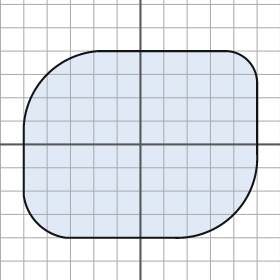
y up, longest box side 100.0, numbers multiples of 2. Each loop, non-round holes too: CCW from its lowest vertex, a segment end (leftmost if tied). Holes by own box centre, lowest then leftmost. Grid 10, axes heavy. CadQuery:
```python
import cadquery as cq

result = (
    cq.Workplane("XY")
    .moveTo(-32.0, -40.0)
    .lineTo(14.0, -40.0)
    .threePointArc((40.0, -30.0), (50.0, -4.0))
    .lineTo(50.0, 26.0)
    .threePointArc((46.0, 36.0), (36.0, 40.0))
    .lineTo(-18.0, 40.0)
    .threePointArc((-40.0, 30.0), (-50.0, 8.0))
    .lineTo(-50.0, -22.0)
    .threePointArc((-44.0, -34.0), (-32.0, -40.0))
    .close()
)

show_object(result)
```